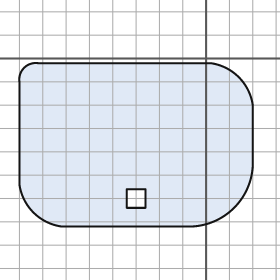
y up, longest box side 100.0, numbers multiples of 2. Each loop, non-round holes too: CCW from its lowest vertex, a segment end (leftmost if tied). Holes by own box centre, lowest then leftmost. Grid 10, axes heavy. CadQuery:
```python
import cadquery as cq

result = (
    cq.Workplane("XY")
    .moveTo(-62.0, -72.0)
    .lineTo(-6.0, -72.0)
    .threePointArc((12.0, -64.0), (20.0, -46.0))
    .lineTo(20.0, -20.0)
    .threePointArc((14.0, -8.0), (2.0, -2.0))
    .lineTo(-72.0, -2.0)
    .threePointArc((-78.0, -4.0), (-80.0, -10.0))
    .lineTo(-80.0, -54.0)
    .threePointArc((-74.0, -66.0), (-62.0, -72.0))
    .close()
    .moveTo(-34.0, -64.0)
    .lineTo(-26.0, -64.0)
    .lineTo(-26.0, -56.0)
    .lineTo(-34.0, -56.0)
    .close()
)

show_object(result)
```